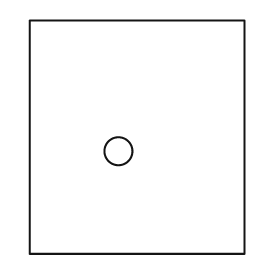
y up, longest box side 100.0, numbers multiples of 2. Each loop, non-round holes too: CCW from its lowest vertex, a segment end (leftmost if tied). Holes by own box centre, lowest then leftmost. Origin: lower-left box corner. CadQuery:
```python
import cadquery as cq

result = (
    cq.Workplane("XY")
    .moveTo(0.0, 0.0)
    .lineTo(92.0, 0.0)
    .lineTo(92.0, 100.0)
    .lineTo(0.0, 100.0)
    .close()
    .moveTo(38.0, 44.0)
    .circle(6.0)
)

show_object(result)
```